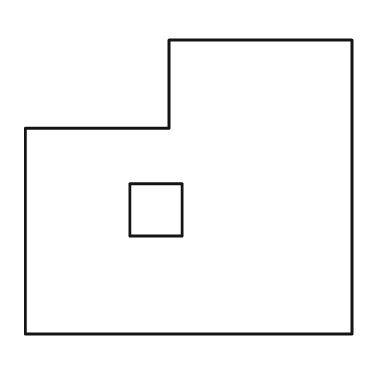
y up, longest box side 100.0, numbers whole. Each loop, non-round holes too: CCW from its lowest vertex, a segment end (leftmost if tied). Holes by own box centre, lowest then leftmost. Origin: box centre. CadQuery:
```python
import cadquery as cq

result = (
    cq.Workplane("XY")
    .moveTo(-50.0, -45.0)
    .lineTo(50.0, -45.0)
    .lineTo(50.0, 45.0)
    .lineTo(-6.0, 45.0)
    .lineTo(-6.0, 18.0)
    .lineTo(-50.0, 18.0)
    .close()
    .moveTo(-18.0, -15.0)
    .lineTo(-2.0, -15.0)
    .lineTo(-2.0, 1.0)
    .lineTo(-18.0, 1.0)
    .close()
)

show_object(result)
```